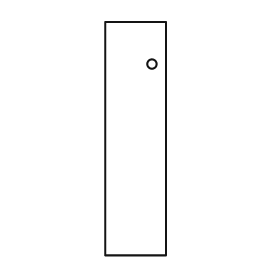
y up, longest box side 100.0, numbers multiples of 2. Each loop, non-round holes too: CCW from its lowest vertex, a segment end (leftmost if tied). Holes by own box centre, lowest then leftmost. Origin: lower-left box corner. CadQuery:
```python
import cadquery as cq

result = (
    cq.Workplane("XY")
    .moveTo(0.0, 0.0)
    .lineTo(26.0, 0.0)
    .lineTo(26.0, 100.0)
    .lineTo(0.0, 100.0)
    .close()
    .moveTo(20.0, 82.0)
    .circle(2.0)
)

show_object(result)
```